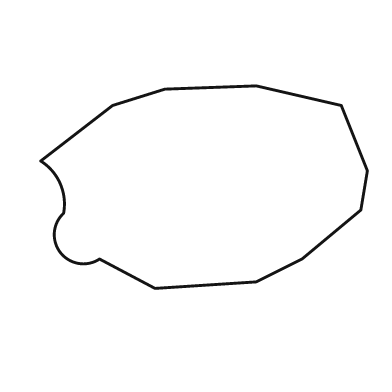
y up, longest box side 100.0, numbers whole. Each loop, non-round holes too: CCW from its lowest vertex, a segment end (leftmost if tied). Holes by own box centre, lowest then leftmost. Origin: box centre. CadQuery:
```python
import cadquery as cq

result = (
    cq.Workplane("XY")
    .moveTo(-15.0, -31.0)
    .lineTo(16.0, -29.0)
    .lineTo(30.0, -22.0)
    .lineTo(48.0, -7.0)
    .lineTo(50.0, 5.0)
    .lineTo(42.0, 25.0)
    .lineTo(16.0, 31.0)
    .lineTo(-12.0, 30.0)
    .lineTo(-28.0, 25.0)
    .lineTo(-50.0, 8.0)
    .threePointArc((-44.0, 1.0), (-43.0, -8.0))
    .threePointArc((-44.0, -20.0), (-32.0, -22.0))
    .close()
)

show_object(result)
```